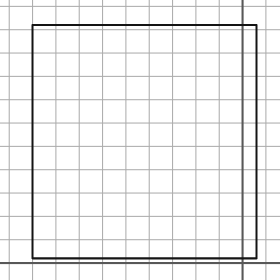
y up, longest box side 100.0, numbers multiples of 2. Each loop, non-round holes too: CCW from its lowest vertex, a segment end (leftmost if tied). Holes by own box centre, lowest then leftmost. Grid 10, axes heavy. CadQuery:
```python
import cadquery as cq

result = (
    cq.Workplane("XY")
    .moveTo(-90.0, 2.0)
    .lineTo(6.0, 2.0)
    .lineTo(6.0, 102.0)
    .lineTo(-90.0, 102.0)
    .close()
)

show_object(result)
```